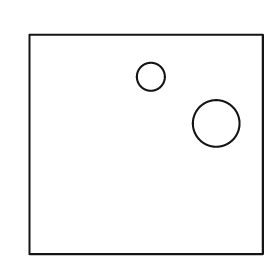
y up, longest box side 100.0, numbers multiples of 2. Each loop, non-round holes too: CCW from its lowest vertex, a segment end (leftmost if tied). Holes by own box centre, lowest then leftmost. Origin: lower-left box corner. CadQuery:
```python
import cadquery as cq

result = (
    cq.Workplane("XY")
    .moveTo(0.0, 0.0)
    .lineTo(100.0, 0.0)
    .lineTo(100.0, 94.0)
    .lineTo(0.0, 94.0)
    .close()
    .moveTo(80.0, 56.0)
    .circle(10.0)
    .moveTo(52.0, 76.0)
    .circle(6.0)
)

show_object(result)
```